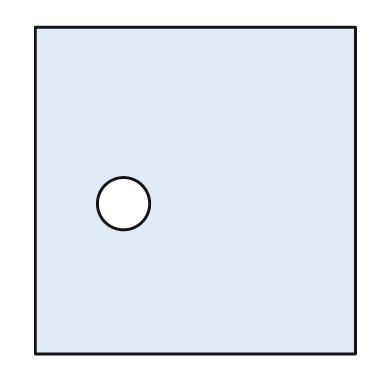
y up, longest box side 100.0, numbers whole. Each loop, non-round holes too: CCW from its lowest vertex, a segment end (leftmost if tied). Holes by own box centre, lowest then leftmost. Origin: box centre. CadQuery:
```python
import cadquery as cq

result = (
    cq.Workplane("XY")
    .moveTo(-49.0, -50.0)
    .lineTo(49.0, -50.0)
    .lineTo(49.0, 50.0)
    .lineTo(-49.0, 50.0)
    .close()
    .moveTo(-22.0, -4.0)
    .circle(8.0)
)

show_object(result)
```